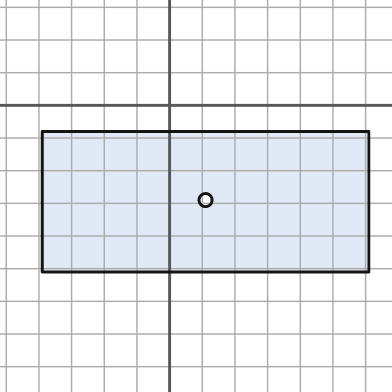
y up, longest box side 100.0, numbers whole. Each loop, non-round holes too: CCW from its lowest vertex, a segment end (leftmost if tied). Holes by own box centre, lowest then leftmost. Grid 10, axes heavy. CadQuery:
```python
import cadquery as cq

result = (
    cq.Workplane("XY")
    .moveTo(-39.0, -51.0)
    .lineTo(61.0, -51.0)
    .lineTo(61.0, -8.0)
    .lineTo(-39.0, -8.0)
    .close()
    .moveTo(11.0, -29.0)
    .circle(2.0)
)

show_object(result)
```